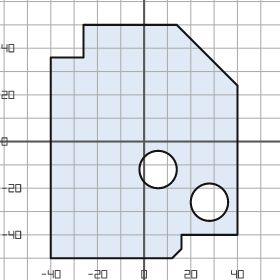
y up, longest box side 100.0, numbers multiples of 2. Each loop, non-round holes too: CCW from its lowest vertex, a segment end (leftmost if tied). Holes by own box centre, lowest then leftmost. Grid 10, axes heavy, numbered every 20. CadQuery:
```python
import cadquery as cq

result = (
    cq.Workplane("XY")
    .moveTo(-40.0, -50.0)
    .lineTo(12.0, -50.0)
    .lineTo(16.0, -46.0)
    .lineTo(16.0, -40.0)
    .lineTo(40.0, -40.0)
    .lineTo(40.0, 24.0)
    .lineTo(14.0, 50.0)
    .lineTo(-26.0, 50.0)
    .lineTo(-26.0, 36.0)
    .lineTo(-40.0, 36.0)
    .close()
    .moveTo(28.0, -26.0)
    .circle(8.0)
    .moveTo(6.0, -12.0)
    .circle(8.0)
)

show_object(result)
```